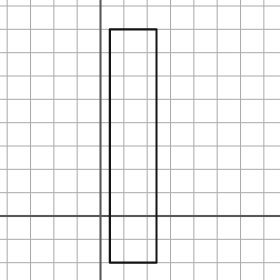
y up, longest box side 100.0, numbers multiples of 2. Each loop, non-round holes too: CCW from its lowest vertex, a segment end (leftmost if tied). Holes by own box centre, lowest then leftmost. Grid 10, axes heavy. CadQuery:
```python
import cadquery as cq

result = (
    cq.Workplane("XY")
    .moveTo(4.0, -20.0)
    .lineTo(24.0, -20.0)
    .lineTo(24.0, 80.0)
    .lineTo(4.0, 80.0)
    .close()
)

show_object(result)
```